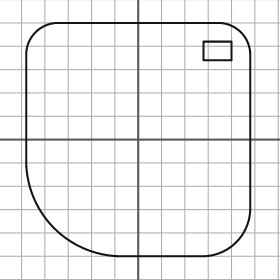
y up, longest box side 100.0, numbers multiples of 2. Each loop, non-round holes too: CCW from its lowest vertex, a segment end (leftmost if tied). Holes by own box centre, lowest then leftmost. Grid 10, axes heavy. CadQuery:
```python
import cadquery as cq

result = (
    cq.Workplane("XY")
    .moveTo(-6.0, -50.0)
    .lineTo(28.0, -50.0)
    .threePointArc((42.0, -44.0), (48.0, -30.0))
    .lineTo(48.0, 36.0)
    .threePointArc((44.0, 46.0), (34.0, 50.0))
    .lineTo(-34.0, 50.0)
    .threePointArc((-44.0, 46.0), (-48.0, 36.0))
    .lineTo(-48.0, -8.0)
    .threePointArc((-36.0, -38.0), (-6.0, -50.0))
    .close()
    .moveTo(28.0, 34.0)
    .lineTo(40.0, 34.0)
    .lineTo(40.0, 42.0)
    .lineTo(28.0, 42.0)
    .close()
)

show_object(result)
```